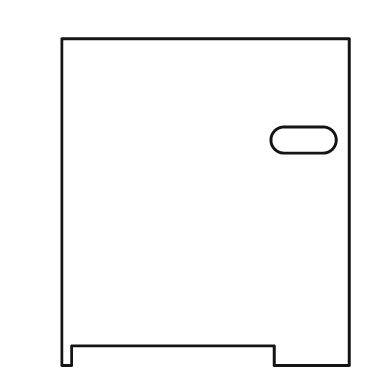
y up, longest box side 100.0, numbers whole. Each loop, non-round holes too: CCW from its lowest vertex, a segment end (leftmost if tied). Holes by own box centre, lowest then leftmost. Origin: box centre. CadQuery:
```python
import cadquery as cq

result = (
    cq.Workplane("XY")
    .moveTo(-44.0, -50.0)
    .lineTo(-41.0, -50.0)
    .lineTo(-41.0, -44.0)
    .lineTo(21.0, -44.0)
    .lineTo(21.0, -50.0)
    .lineTo(44.0, -50.0)
    .lineTo(44.0, 50.0)
    .lineTo(-44.0, 50.0)
    .close()
    .moveTo(24.0, 15.0)
    .lineTo(36.0, 15.0)
    .threePointArc((40.0, 19.0), (36.0, 23.0))
    .lineTo(24.0, 23.0)
    .threePointArc((20.0, 19.0), (24.0, 15.0))
    .close()
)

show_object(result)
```